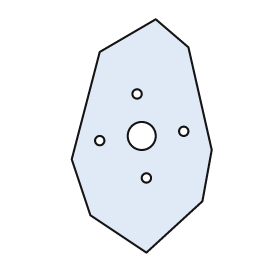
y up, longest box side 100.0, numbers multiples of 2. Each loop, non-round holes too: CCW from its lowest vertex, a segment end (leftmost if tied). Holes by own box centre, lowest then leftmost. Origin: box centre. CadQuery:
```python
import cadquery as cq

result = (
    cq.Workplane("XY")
    .moveTo(2.0, -50.0)
    .lineTo(26.0, -28.0)
    .lineTo(30.0, -6.0)
    .lineTo(20.0, 38.0)
    .lineTo(6.0, 50.0)
    .lineTo(-18.0, 36.0)
    .lineTo(-30.0, -10.0)
    .lineTo(-22.0, -34.0)
    .close()
    .moveTo(2.0, -18.0)
    .circle(2.0)
    .moveTo(-18.0, -2.0)
    .circle(2.0)
    .moveTo(0.0, 0.0)
    .circle(6.0)
    .moveTo(18.0, 2.0)
    .circle(2.0)
    .moveTo(-2.0, 18.0)
    .circle(2.0)
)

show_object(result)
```